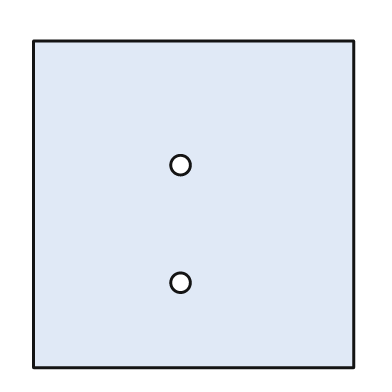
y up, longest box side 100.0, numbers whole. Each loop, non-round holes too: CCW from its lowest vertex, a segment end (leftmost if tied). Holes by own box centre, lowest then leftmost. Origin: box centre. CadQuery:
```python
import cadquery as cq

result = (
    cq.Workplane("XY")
    .moveTo(-49.0, -50.0)
    .lineTo(49.0, -50.0)
    .lineTo(49.0, 50.0)
    .lineTo(-49.0, 50.0)
    .close()
    .moveTo(-4.0, -24.0)
    .circle(3.0)
    .moveTo(-4.0, 12.0)
    .circle(3.0)
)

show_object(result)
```